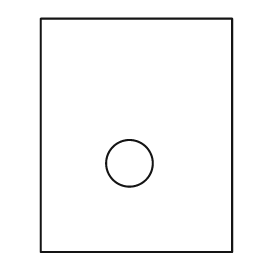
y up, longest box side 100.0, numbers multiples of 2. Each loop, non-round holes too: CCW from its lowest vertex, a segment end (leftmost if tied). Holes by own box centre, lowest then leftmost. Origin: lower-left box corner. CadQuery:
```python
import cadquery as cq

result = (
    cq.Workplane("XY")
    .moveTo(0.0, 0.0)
    .lineTo(82.0, 0.0)
    .lineTo(82.0, 100.0)
    .lineTo(0.0, 100.0)
    .close()
    .moveTo(38.0, 38.0)
    .circle(10.0)
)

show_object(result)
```